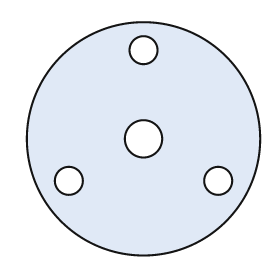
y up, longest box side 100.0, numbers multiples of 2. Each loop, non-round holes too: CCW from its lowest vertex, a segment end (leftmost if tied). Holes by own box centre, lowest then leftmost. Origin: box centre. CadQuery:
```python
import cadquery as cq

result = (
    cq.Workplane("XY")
    .moveTo(0.0, 0.0)
    .circle(50.0)
    .moveTo(-32.0, -18.0)
    .circle(6.0)
    .moveTo(32.0, -18.0)
    .circle(6.0)
    .moveTo(0.0, 0.0)
    .circle(8.0)
    .moveTo(0.0, 38.0)
    .circle(6.0)
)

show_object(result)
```